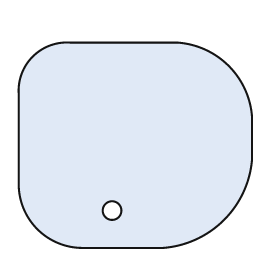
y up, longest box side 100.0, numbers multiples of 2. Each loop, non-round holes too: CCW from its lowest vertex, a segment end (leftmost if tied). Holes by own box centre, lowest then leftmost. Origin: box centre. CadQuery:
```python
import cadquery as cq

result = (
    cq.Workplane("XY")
    .moveTo(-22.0, -44.0)
    .lineTo(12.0, -44.0)
    .threePointArc((38.0, -32.0), (50.0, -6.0))
    .lineTo(50.0, 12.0)
    .threePointArc((40.0, 34.0), (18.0, 44.0))
    .lineTo(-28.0, 44.0)
    .threePointArc((-44.0, 38.0), (-50.0, 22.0))
    .lineTo(-50.0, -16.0)
    .threePointArc((-42.0, -36.0), (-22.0, -44.0))
    .close()
    .moveTo(-10.0, -28.0)
    .circle(4.0)
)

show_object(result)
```